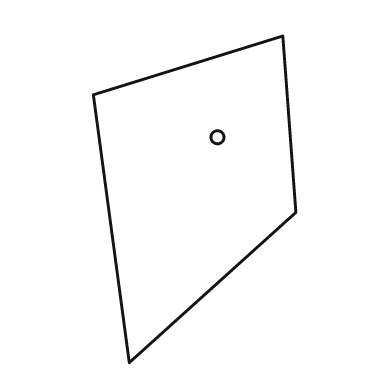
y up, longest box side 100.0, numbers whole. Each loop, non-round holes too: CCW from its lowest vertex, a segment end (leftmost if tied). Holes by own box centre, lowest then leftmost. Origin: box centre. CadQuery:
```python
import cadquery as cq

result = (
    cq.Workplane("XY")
    .moveTo(-20.0, -50.0)
    .lineTo(31.0, -4.0)
    .lineTo(27.0, 50.0)
    .lineTo(-31.0, 32.0)
    .close()
    .moveTo(7.0, 19.0)
    .circle(2.0)
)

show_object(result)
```